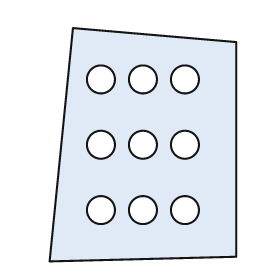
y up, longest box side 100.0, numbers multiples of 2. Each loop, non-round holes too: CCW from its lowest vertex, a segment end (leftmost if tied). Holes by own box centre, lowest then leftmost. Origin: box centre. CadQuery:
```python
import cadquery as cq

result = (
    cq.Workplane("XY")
    .moveTo(-40.0, -50.0)
    .lineTo(40.0, -48.0)
    .lineTo(40.0, 44.0)
    .lineTo(-30.0, 50.0)
    .close()
    .moveTo(-18.0, -28.0)
    .circle(6.0)
    .moveTo(0.0, -28.0)
    .circle(6.0)
    .moveTo(18.0, -28.0)
    .circle(6.0)
    .moveTo(-18.0, 0.0)
    .circle(6.0)
    .moveTo(0.0, 0.0)
    .circle(6.0)
    .moveTo(18.0, 0.0)
    .circle(6.0)
    .moveTo(-18.0, 28.0)
    .circle(6.0)
    .moveTo(0.0, 28.0)
    .circle(6.0)
    .moveTo(18.0, 28.0)
    .circle(6.0)
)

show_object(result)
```